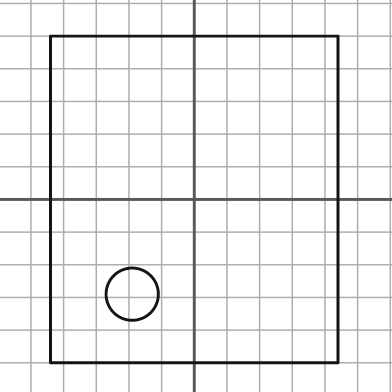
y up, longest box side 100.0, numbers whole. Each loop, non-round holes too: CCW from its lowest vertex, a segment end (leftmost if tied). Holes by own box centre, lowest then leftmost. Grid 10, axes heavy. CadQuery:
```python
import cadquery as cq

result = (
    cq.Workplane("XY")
    .moveTo(-44.0, -50.0)
    .lineTo(44.0, -50.0)
    .lineTo(44.0, 50.0)
    .lineTo(-44.0, 50.0)
    .close()
    .moveTo(-19.0, -29.0)
    .circle(8.0)
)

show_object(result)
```